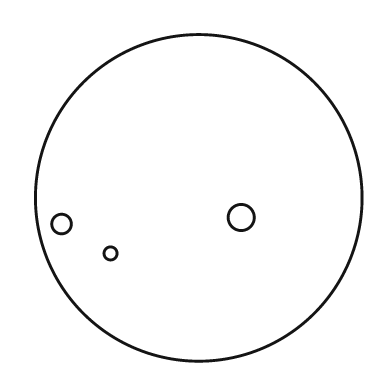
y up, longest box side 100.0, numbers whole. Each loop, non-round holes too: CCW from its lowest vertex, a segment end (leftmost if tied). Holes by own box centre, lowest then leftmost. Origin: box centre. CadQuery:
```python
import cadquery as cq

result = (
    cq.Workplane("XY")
    .moveTo(0.0, 0.0)
    .circle(50.0)
    .moveTo(-27.0, -17.0)
    .circle(2.0)
    .moveTo(-42.0, -8.0)
    .circle(3.0)
    .moveTo(13.0, -6.0)
    .circle(4.0)
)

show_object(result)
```